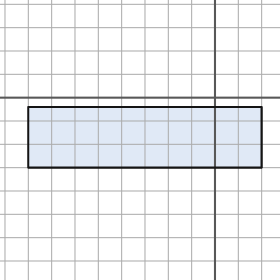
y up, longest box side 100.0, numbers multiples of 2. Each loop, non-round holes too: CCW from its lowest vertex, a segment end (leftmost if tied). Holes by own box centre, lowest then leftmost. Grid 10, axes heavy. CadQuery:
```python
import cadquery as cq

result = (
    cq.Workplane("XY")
    .moveTo(-80.0, -30.0)
    .lineTo(20.0, -30.0)
    .lineTo(20.0, -4.0)
    .lineTo(-80.0, -4.0)
    .close()
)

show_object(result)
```